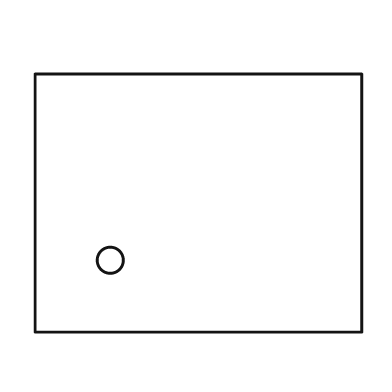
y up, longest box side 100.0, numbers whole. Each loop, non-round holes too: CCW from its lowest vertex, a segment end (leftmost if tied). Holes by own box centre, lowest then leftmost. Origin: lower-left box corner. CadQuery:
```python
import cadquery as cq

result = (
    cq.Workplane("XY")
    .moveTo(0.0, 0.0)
    .lineTo(100.0, 0.0)
    .lineTo(100.0, 79.0)
    .lineTo(0.0, 79.0)
    .close()
    .moveTo(23.0, 22.0)
    .circle(4.0)
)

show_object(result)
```